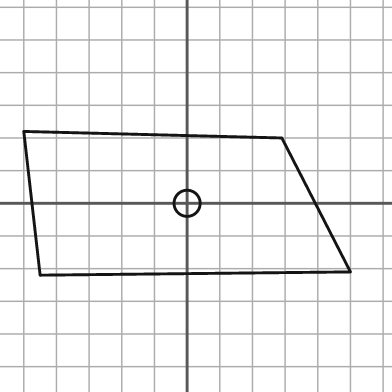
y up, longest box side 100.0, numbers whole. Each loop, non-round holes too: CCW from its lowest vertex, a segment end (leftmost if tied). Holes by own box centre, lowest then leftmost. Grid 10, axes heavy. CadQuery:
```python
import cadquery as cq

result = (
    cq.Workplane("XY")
    .moveTo(-45.0, -22.0)
    .lineTo(50.0, -21.0)
    .lineTo(29.0, 20.0)
    .lineTo(-50.0, 22.0)
    .close()
    .moveTo(0.0, 0.0)
    .circle(4.0)
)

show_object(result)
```